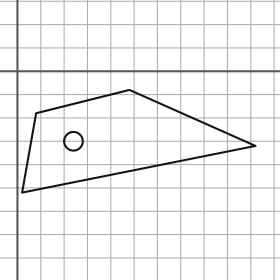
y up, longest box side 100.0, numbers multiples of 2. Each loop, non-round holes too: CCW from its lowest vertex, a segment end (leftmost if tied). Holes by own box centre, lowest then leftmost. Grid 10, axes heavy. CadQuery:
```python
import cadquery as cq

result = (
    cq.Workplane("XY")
    .moveTo(2.0, -52.0)
    .lineTo(102.0, -32.0)
    .lineTo(48.0, -8.0)
    .lineTo(8.0, -18.0)
    .close()
    .moveTo(24.0, -30.0)
    .circle(4.0)
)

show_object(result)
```